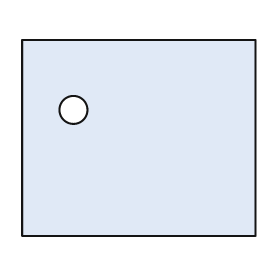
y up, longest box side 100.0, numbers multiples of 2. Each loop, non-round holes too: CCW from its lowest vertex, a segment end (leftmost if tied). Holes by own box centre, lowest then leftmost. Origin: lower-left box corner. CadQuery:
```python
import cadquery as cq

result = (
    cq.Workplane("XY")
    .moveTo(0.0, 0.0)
    .lineTo(100.0, 0.0)
    .lineTo(100.0, 84.0)
    .lineTo(0.0, 84.0)
    .close()
    .moveTo(22.0, 54.0)
    .circle(6.0)
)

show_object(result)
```